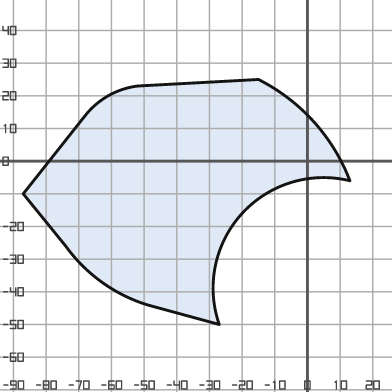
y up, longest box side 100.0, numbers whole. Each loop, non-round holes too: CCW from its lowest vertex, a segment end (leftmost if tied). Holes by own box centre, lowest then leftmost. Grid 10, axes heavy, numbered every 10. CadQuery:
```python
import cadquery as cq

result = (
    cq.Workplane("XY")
    .moveTo(-27.0, -50.0)
    .threePointArc((-20.0, -16.0), (13.0, -6.0))
    .threePointArc((2.0, 12.0), (-15.0, 25.0))
    .lineTo(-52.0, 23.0)
    .threePointArc((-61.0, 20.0), (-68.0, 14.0))
    .lineTo(-87.0, -10.0)
    .lineTo(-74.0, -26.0)
    .threePointArc((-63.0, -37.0), (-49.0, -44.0))
    .close()
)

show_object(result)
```